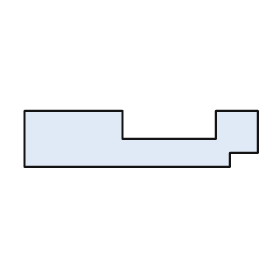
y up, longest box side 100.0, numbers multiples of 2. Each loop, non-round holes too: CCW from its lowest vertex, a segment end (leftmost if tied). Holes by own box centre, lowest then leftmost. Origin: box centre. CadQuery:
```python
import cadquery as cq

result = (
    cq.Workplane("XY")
    .moveTo(-50.0, -12.0)
    .lineTo(38.0, -12.0)
    .lineTo(38.0, -6.0)
    .lineTo(50.0, -6.0)
    .lineTo(50.0, 12.0)
    .lineTo(32.0, 12.0)
    .lineTo(32.0, 0.0)
    .lineTo(-8.0, 0.0)
    .lineTo(-8.0, 12.0)
    .lineTo(-50.0, 12.0)
    .close()
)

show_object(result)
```